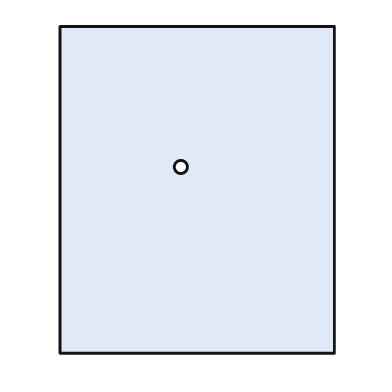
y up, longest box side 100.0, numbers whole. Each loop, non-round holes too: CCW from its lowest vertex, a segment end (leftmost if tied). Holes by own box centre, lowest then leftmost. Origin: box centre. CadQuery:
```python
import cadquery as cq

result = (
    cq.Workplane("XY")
    .moveTo(-42.0, -50.0)
    .lineTo(42.0, -50.0)
    .lineTo(42.0, 50.0)
    .lineTo(-42.0, 50.0)
    .close()
    .moveTo(-5.0, 7.0)
    .circle(2.0)
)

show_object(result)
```